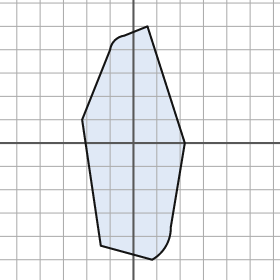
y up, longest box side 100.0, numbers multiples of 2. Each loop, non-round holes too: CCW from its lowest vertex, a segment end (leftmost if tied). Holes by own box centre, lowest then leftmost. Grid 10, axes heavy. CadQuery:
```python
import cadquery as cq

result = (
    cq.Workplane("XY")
    .moveTo(8.0, -50.0)
    .threePointArc((14.0, -44.0), (16.0, -36.0))
    .lineTo(22.0, 0.0)
    .lineTo(6.0, 50.0)
    .lineTo(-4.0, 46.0)
    .threePointArc((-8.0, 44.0), (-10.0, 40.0))
    .lineTo(-22.0, 10.0)
    .lineTo(-14.0, -44.0)
    .close()
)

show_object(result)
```